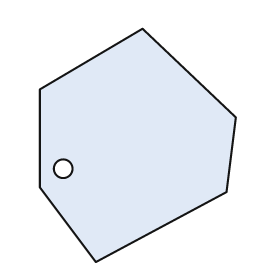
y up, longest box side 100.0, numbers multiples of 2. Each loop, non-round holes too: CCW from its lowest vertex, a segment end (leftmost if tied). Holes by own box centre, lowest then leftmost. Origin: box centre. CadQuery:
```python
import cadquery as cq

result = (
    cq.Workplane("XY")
    .moveTo(-18.0, -50.0)
    .lineTo(38.0, -20.0)
    .lineTo(42.0, 12.0)
    .lineTo(2.0, 50.0)
    .lineTo(-42.0, 24.0)
    .lineTo(-42.0, -18.0)
    .close()
    .moveTo(-32.0, -10.0)
    .circle(4.0)
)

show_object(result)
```